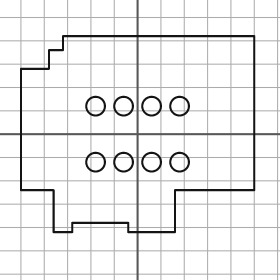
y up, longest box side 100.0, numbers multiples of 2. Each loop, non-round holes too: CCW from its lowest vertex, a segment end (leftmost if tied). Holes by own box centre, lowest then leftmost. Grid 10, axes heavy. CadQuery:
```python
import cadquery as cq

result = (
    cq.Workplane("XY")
    .moveTo(-36.0, -42.0)
    .lineTo(-28.0, -42.0)
    .lineTo(-28.0, -38.0)
    .lineTo(-4.0, -38.0)
    .lineTo(-4.0, -42.0)
    .lineTo(16.0, -42.0)
    .lineTo(16.0, -24.0)
    .lineTo(50.0, -24.0)
    .lineTo(50.0, 42.0)
    .lineTo(-32.0, 42.0)
    .lineTo(-32.0, 36.0)
    .lineTo(-38.0, 36.0)
    .lineTo(-38.0, 28.0)
    .lineTo(-50.0, 28.0)
    .lineTo(-50.0, -24.0)
    .lineTo(-36.0, -24.0)
    .close()
    .moveTo(-18.0, -12.0)
    .circle(4.0)
    .moveTo(-6.0, -12.0)
    .circle(4.0)
    .moveTo(6.0, -12.0)
    .circle(4.0)
    .moveTo(18.0, -12.0)
    .circle(4.0)
    .moveTo(-18.0, 12.0)
    .circle(4.0)
    .moveTo(-6.0, 12.0)
    .circle(4.0)
    .moveTo(6.0, 12.0)
    .circle(4.0)
    .moveTo(18.0, 12.0)
    .circle(4.0)
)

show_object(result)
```